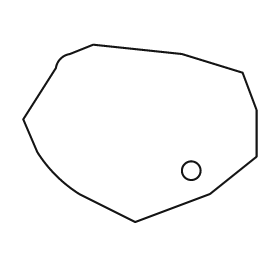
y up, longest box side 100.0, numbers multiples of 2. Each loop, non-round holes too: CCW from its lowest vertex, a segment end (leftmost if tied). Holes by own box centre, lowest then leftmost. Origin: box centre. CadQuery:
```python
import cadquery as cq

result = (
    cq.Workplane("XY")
    .moveTo(-2.0, -38.0)
    .lineTo(30.0, -26.0)
    .lineTo(50.0, -10.0)
    .lineTo(50.0, 10.0)
    .lineTo(44.0, 26.0)
    .lineTo(18.0, 34.0)
    .lineTo(-20.0, 38.0)
    .lineTo(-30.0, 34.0)
    .threePointArc((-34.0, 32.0), (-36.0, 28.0))
    .lineTo(-50.0, 6.0)
    .lineTo(-44.0, -8.0)
    .threePointArc((-36.0, -18.0), (-26.0, -26.0))
    .close()
    .moveTo(22.0, -16.0)
    .circle(4.0)
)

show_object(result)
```